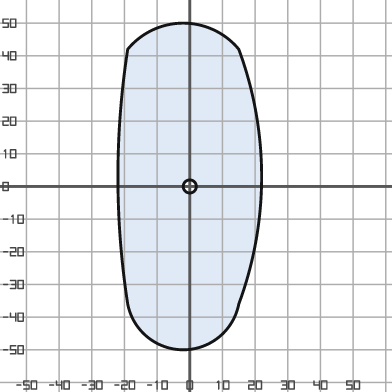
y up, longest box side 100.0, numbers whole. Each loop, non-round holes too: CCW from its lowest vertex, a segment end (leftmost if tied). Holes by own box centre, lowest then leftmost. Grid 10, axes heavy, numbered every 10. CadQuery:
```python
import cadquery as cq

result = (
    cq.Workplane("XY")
    .moveTo(-19.0, -36.0)
    .threePointArc((-2.0, -50.0), (15.0, -36.0))
    .threePointArc((22.0, 3.0), (15.0, 42.0))
    .threePointArc((-2.0, 50.0), (-19.0, 42.0))
    .threePointArc((-22.0, 3.0), (-19.0, -36.0))
    .close()
    .moveTo(0.0, 0.0)
    .circle(2.0)
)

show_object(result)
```